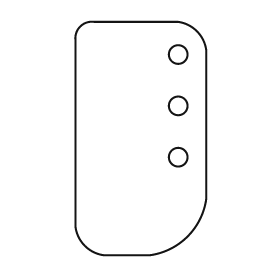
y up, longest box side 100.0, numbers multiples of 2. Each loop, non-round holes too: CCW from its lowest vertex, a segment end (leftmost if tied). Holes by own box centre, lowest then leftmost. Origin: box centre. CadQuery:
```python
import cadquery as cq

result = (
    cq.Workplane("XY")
    .moveTo(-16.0, -50.0)
    .lineTo(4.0, -50.0)
    .threePointArc((20.0, -42.0), (28.0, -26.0))
    .lineTo(28.0, 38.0)
    .threePointArc((24.0, 46.0), (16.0, 50.0))
    .lineTo(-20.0, 50.0)
    .threePointArc((-26.0, 48.0), (-28.0, 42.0))
    .lineTo(-28.0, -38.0)
    .threePointArc((-24.0, -46.0), (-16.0, -50.0))
    .close()
    .moveTo(16.0, -8.0)
    .circle(4.0)
    .moveTo(16.0, 14.0)
    .circle(4.0)
    .moveTo(16.0, 36.0)
    .circle(4.0)
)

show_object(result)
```